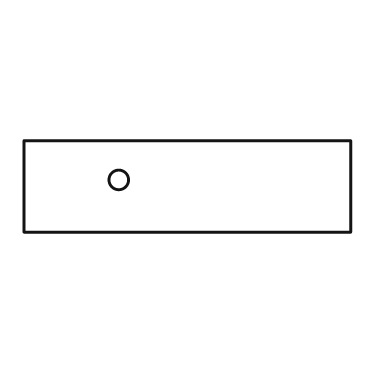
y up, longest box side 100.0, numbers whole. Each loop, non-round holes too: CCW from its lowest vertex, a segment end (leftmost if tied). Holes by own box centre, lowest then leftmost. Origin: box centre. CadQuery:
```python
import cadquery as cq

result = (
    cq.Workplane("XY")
    .moveTo(-50.0, -14.0)
    .lineTo(50.0, -14.0)
    .lineTo(50.0, 14.0)
    .lineTo(-50.0, 14.0)
    .close()
    .moveTo(-21.0, 2.0)
    .circle(3.0)
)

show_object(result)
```